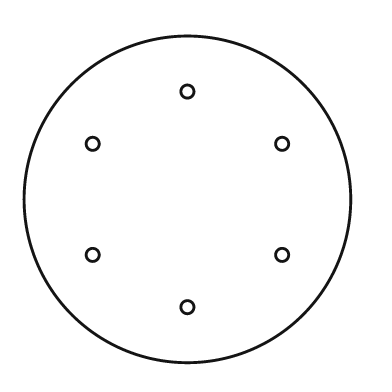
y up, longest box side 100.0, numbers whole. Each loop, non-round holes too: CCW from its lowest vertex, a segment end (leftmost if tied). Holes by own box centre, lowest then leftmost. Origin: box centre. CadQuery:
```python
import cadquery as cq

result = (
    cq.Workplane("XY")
    .moveTo(0.0, 0.0)
    .circle(50.0)
    .moveTo(0.0, -33.0)
    .circle(2.0)
    .moveTo(-29.0, -17.0)
    .circle(2.0)
    .moveTo(29.0, -17.0)
    .circle(2.0)
    .moveTo(-29.0, 17.0)
    .circle(2.0)
    .moveTo(29.0, 17.0)
    .circle(2.0)
    .moveTo(0.0, 33.0)
    .circle(2.0)
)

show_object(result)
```